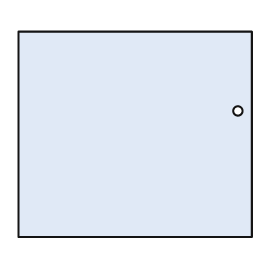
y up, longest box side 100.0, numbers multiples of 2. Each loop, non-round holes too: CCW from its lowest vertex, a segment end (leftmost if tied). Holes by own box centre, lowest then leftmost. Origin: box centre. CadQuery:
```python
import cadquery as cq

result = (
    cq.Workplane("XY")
    .moveTo(-50.0, -44.0)
    .lineTo(50.0, -44.0)
    .lineTo(50.0, 44.0)
    .lineTo(-50.0, 44.0)
    .close()
    .moveTo(44.0, 10.0)
    .circle(2.0)
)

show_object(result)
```